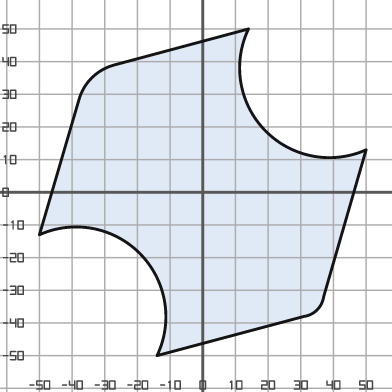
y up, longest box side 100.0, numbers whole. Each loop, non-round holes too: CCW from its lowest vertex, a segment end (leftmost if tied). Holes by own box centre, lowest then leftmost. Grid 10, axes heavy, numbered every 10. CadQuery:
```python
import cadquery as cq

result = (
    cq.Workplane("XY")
    .moveTo(-14.0, -50.0)
    .lineTo(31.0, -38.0)
    .threePointArc((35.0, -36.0), (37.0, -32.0))
    .lineTo(50.0, 13.0)
    .threePointArc((19.0, 19.0), (14.0, 50.0))
    .lineTo(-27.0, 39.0)
    .threePointArc((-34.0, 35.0), (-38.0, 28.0))
    .lineTo(-50.0, -13.0)
    .threePointArc((-19.0, -19.0), (-14.0, -50.0))
    .close()
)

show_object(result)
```